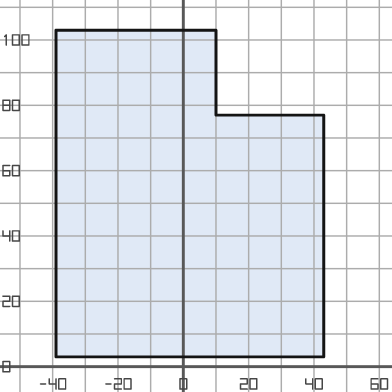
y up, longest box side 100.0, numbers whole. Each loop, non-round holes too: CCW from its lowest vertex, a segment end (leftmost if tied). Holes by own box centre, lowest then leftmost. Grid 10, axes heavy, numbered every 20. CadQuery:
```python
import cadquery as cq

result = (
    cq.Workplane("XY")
    .moveTo(-39.0, 3.0)
    .lineTo(43.0, 3.0)
    .lineTo(43.0, 77.0)
    .lineTo(10.0, 77.0)
    .lineTo(10.0, 103.0)
    .lineTo(-39.0, 103.0)
    .close()
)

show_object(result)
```